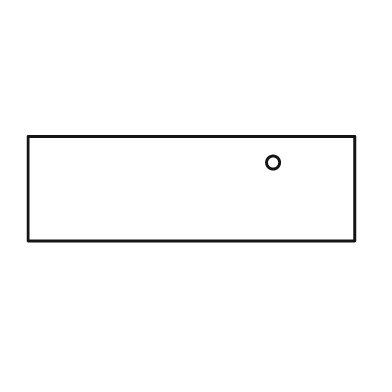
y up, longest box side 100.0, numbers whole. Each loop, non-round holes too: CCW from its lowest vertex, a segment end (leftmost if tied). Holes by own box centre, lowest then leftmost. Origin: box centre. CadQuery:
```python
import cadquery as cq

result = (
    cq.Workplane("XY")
    .moveTo(-50.0, -16.0)
    .lineTo(50.0, -16.0)
    .lineTo(50.0, 16.0)
    .lineTo(-50.0, 16.0)
    .close()
    .moveTo(25.0, 8.0)
    .circle(2.0)
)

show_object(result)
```